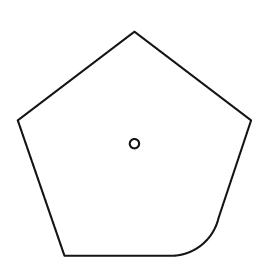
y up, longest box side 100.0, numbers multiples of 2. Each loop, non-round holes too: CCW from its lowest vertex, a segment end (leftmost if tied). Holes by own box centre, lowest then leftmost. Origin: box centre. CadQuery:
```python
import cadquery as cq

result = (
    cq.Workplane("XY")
    .moveTo(-30.0, -48.0)
    .lineTo(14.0, -48.0)
    .threePointArc((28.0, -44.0), (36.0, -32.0))
    .lineTo(50.0, 10.0)
    .lineTo(0.0, 48.0)
    .lineTo(-50.0, 10.0)
    .close()
    .moveTo(0.0, 0.0)
    .circle(2.0)
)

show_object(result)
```